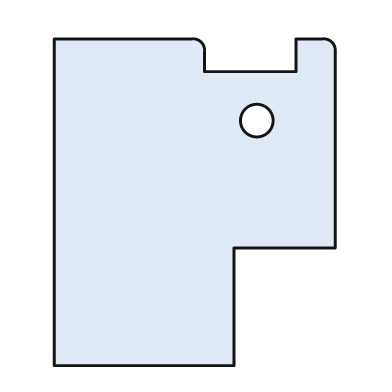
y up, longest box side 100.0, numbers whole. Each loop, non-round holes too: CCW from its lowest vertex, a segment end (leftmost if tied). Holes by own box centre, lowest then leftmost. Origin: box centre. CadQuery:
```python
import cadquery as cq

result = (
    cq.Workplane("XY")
    .moveTo(-43.0, -50.0)
    .lineTo(12.0, -50.0)
    .lineTo(12.0, -14.0)
    .lineTo(43.0, -14.0)
    .lineTo(43.0, 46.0)
    .threePointArc((42.0, 49.0), (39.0, 50.0))
    .lineTo(31.0, 50.0)
    .lineTo(31.0, 40.0)
    .lineTo(3.0, 40.0)
    .lineTo(3.0, 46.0)
    .threePointArc((2.0, 49.0), (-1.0, 50.0))
    .lineTo(-43.0, 50.0)
    .close()
    .moveTo(19.0, 25.0)
    .circle(5.0)
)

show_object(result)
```